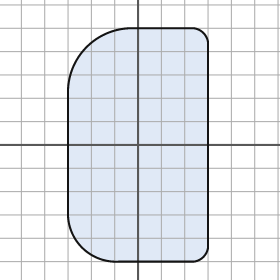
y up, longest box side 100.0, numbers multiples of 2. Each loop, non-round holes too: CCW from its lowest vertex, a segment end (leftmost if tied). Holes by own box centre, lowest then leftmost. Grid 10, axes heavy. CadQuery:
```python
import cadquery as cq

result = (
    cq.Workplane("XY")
    .moveTo(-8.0, -50.0)
    .lineTo(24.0, -50.0)
    .threePointArc((28.0, -48.0), (30.0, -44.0))
    .lineTo(30.0, 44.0)
    .threePointArc((28.0, 48.0), (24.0, 50.0))
    .lineTo(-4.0, 50.0)
    .threePointArc((-22.0, 42.0), (-30.0, 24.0))
    .lineTo(-30.0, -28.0)
    .threePointArc((-24.0, -44.0), (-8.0, -50.0))
    .close()
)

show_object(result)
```